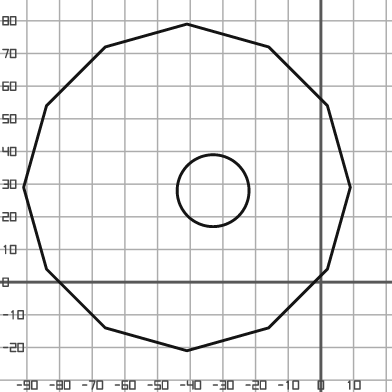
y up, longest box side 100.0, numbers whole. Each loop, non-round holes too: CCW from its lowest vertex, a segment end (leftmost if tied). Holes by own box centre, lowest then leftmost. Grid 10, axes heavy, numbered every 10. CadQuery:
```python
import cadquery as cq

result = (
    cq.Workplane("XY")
    .moveTo(-41.0, -21.0)
    .lineTo(-16.0, -14.0)
    .lineTo(2.0, 4.0)
    .lineTo(9.0, 29.0)
    .lineTo(2.0, 54.0)
    .lineTo(-16.0, 72.0)
    .lineTo(-41.0, 79.0)
    .lineTo(-66.0, 72.0)
    .lineTo(-84.0, 54.0)
    .lineTo(-91.0, 29.0)
    .lineTo(-84.0, 4.0)
    .lineTo(-66.0, -14.0)
    .close()
    .moveTo(-33.0, 28.0)
    .circle(11.0)
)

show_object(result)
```